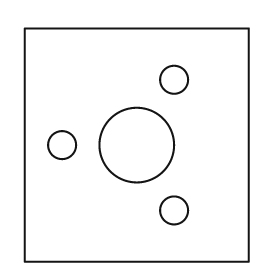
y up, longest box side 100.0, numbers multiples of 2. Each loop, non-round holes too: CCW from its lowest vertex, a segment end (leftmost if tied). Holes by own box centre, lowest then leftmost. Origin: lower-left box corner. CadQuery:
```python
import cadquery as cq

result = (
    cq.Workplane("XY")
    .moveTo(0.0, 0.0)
    .lineTo(96.0, 0.0)
    .lineTo(96.0, 100.0)
    .lineTo(0.0, 100.0)
    .close()
    .moveTo(64.0, 22.0)
    .circle(6.0)
    .moveTo(16.0, 50.0)
    .circle(6.0)
    .moveTo(48.0, 50.0)
    .circle(16.0)
    .moveTo(64.0, 78.0)
    .circle(6.0)
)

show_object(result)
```